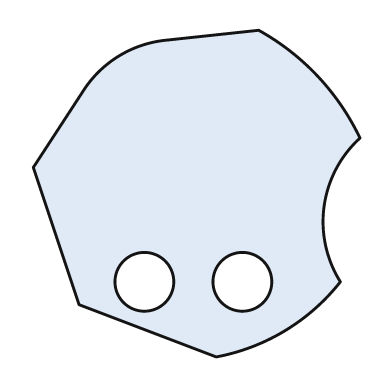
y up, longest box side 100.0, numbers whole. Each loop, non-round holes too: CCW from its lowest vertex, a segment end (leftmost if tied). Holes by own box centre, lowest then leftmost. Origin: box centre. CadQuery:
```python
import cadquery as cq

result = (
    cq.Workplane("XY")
    .moveTo(6.0, -50.0)
    .threePointArc((27.0, -42.0), (44.0, -27.0))
    .threePointArc((39.0, -4.0), (50.0, 17.0))
    .threePointArc((37.0, 36.0), (19.0, 50.0))
    .lineTo(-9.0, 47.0)
    .threePointArc((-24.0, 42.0), (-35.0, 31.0))
    .lineTo(-50.0, 8.0)
    .lineTo(-36.0, -34.0)
    .close()
    .moveTo(-16.0, -27.0)
    .circle(9.0)
    .moveTo(14.0, -27.0)
    .circle(9.0)
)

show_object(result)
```